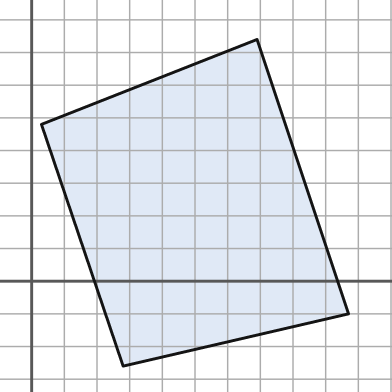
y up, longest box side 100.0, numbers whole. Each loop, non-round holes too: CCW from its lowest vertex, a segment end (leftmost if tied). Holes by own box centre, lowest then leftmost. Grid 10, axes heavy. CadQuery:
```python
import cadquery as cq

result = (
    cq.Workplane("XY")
    .moveTo(28.0, -26.0)
    .lineTo(97.0, -10.0)
    .lineTo(69.0, 74.0)
    .lineTo(3.0, 48.0)
    .close()
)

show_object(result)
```